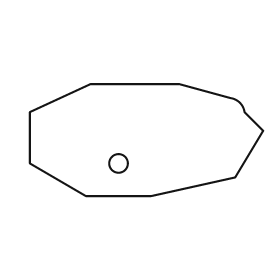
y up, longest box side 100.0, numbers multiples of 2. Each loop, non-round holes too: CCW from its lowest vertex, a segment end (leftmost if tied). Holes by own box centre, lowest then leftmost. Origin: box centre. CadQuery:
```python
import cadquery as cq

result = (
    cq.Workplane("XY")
    .moveTo(-26.0, -24.0)
    .lineTo(2.0, -24.0)
    .lineTo(38.0, -16.0)
    .lineTo(50.0, 4.0)
    .lineTo(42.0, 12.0)
    .threePointArc((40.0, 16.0), (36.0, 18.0))
    .lineTo(14.0, 24.0)
    .lineTo(-24.0, 24.0)
    .lineTo(-50.0, 12.0)
    .lineTo(-50.0, -10.0)
    .close()
    .moveTo(-12.0, -10.0)
    .circle(4.0)
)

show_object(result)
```